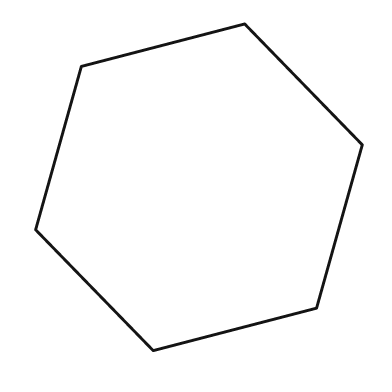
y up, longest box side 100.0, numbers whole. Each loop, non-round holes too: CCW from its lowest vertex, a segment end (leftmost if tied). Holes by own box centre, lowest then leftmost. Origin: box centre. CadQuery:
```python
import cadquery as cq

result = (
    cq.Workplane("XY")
    .moveTo(-14.0, -50.0)
    .lineTo(36.0, -37.0)
    .lineTo(50.0, 13.0)
    .lineTo(14.0, 50.0)
    .lineTo(-36.0, 37.0)
    .lineTo(-50.0, -13.0)
    .close()
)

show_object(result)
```